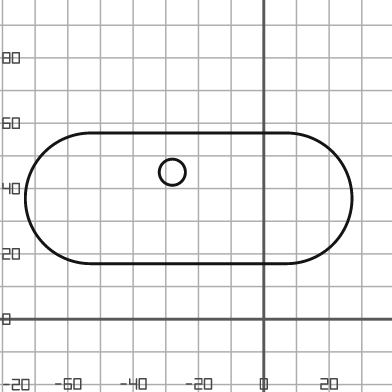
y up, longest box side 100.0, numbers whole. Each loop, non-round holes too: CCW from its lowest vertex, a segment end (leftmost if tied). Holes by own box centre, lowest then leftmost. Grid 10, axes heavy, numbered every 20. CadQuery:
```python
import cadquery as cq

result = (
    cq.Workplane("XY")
    .moveTo(-53.0, 17.0)
    .lineTo(7.0, 17.0)
    .threePointArc((27.0, 37.0), (7.0, 57.0))
    .lineTo(-53.0, 57.0)
    .threePointArc((-73.0, 37.0), (-53.0, 17.0))
    .close()
    .moveTo(-28.0, 45.0)
    .circle(4.0)
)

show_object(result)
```